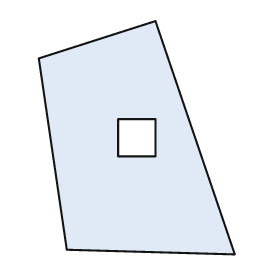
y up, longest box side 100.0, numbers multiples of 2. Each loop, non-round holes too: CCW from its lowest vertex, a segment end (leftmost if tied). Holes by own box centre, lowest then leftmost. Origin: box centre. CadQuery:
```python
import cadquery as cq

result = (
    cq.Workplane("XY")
    .moveTo(42.0, -50.0)
    .lineTo(8.0, 50.0)
    .lineTo(-42.0, 34.0)
    .lineTo(-30.0, -48.0)
    .close()
    .moveTo(-8.0, -8.0)
    .lineTo(8.0, -8.0)
    .lineTo(8.0, 8.0)
    .lineTo(-8.0, 8.0)
    .close()
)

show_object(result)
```